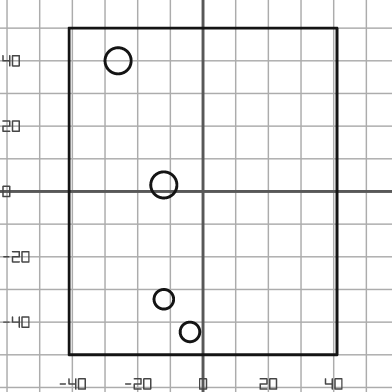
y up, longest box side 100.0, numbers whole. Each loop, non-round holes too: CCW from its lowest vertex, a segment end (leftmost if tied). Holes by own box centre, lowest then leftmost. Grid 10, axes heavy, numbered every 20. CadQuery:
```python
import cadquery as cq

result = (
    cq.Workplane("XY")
    .moveTo(-41.0, -50.0)
    .lineTo(41.0, -50.0)
    .lineTo(41.0, 50.0)
    .lineTo(-41.0, 50.0)
    .close()
    .moveTo(-4.0, -43.0)
    .circle(3.0)
    .moveTo(-12.0, -33.0)
    .circle(3.0)
    .moveTo(-12.0, 2.0)
    .circle(4.0)
    .moveTo(-26.0, 40.0)
    .circle(4.0)
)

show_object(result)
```